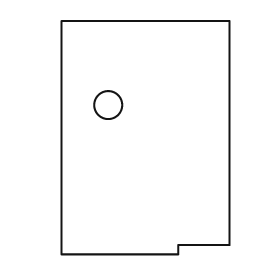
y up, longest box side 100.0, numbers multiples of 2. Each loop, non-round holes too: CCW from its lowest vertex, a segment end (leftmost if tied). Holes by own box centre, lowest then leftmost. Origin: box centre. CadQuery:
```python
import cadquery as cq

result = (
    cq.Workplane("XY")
    .moveTo(-36.0, -50.0)
    .lineTo(14.0, -50.0)
    .lineTo(14.0, -46.0)
    .lineTo(36.0, -46.0)
    .lineTo(36.0, 50.0)
    .lineTo(-36.0, 50.0)
    .close()
    .moveTo(-16.0, 14.0)
    .circle(6.0)
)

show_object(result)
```